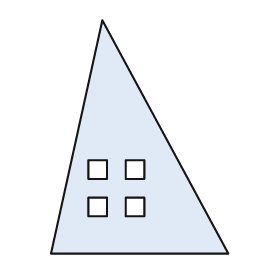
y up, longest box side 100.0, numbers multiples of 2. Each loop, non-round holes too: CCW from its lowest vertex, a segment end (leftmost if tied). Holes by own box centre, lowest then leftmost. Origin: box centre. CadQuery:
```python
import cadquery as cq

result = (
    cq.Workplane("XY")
    .moveTo(-38.0, -50.0)
    .lineTo(38.0, -50.0)
    .lineTo(-16.0, 50.0)
    .close()
    .moveTo(-22.0, -34.0)
    .lineTo(-14.0, -34.0)
    .lineTo(-14.0, -26.0)
    .lineTo(-22.0, -26.0)
    .close()
    .moveTo(-6.0, -34.0)
    .lineTo(2.0, -34.0)
    .lineTo(2.0, -26.0)
    .lineTo(-6.0, -26.0)
    .close()
    .moveTo(-22.0, -18.0)
    .lineTo(-14.0, -18.0)
    .lineTo(-14.0, -10.0)
    .lineTo(-22.0, -10.0)
    .close()
    .moveTo(-6.0, -18.0)
    .lineTo(2.0, -18.0)
    .lineTo(2.0, -10.0)
    .lineTo(-6.0, -10.0)
    .close()
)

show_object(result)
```